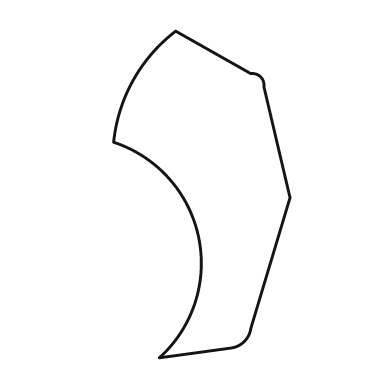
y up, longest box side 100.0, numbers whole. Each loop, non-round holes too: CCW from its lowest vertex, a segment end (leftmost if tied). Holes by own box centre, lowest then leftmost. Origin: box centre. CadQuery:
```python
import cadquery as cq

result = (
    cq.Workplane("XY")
    .moveTo(-13.0, -50.0)
    .lineTo(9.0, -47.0)
    .threePointArc((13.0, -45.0), (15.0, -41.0))
    .lineTo(27.0, -1.0)
    .lineTo(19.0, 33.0)
    .threePointArc((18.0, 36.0), (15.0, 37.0))
    .lineTo(-8.0, 50.0)
    .threePointArc((-21.0, 35.0), (-27.0, 16.0))
    .threePointArc((-1.0, -13.0), (-13.0, -50.0))
    .close()
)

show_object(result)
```